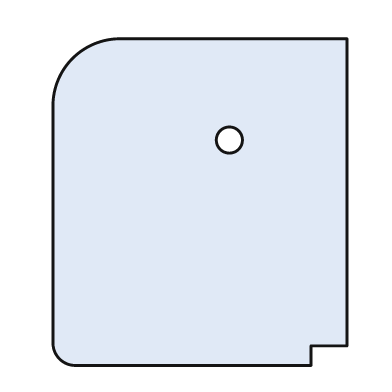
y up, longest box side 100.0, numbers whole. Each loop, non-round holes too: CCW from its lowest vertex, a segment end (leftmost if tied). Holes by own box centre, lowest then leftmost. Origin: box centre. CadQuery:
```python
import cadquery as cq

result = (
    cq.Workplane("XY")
    .moveTo(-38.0, -50.0)
    .lineTo(34.0, -50.0)
    .lineTo(34.0, -44.0)
    .lineTo(45.0, -44.0)
    .lineTo(45.0, 50.0)
    .lineTo(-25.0, 50.0)
    .threePointArc((-39.0, 44.0), (-45.0, 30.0))
    .lineTo(-45.0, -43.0)
    .threePointArc((-43.0, -48.0), (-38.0, -50.0))
    .close()
    .moveTo(9.0, 19.0)
    .circle(4.0)
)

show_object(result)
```